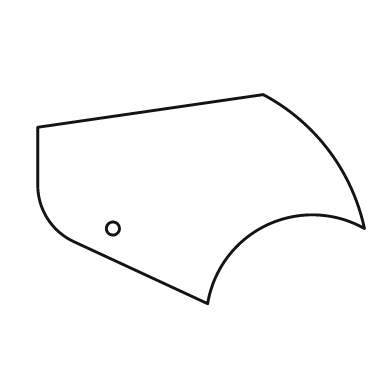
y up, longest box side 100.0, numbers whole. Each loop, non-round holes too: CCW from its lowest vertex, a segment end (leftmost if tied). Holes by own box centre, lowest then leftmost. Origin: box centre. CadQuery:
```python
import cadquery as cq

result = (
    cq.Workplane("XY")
    .moveTo(2.0, -32.0)
    .threePointArc((20.0, -8.0), (50.0, -9.0))
    .threePointArc((39.0, 15.0), (19.0, 32.0))
    .lineTo(-50.0, 22.0)
    .lineTo(-50.0, 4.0)
    .threePointArc((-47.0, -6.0), (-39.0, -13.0))
    .close()
    .moveTo(-27.0, -9.0)
    .circle(2.0)
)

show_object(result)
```